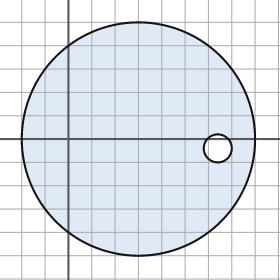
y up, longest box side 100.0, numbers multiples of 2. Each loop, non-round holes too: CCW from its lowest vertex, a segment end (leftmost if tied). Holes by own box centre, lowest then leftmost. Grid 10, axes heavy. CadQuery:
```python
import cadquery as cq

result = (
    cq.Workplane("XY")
    .moveTo(30.0, 0.0)
    .circle(50.0)
    .moveTo(64.0, -4.0)
    .circle(6.0)
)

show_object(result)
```